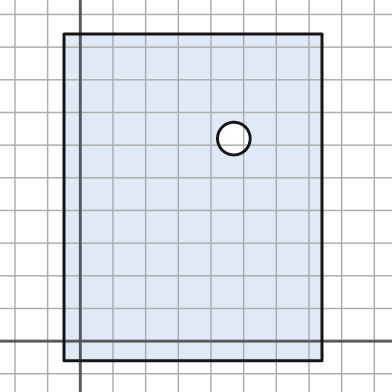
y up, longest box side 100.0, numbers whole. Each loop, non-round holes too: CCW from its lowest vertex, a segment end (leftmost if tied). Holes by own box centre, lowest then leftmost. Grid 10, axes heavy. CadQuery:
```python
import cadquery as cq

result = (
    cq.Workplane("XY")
    .moveTo(-5.0, -6.0)
    .lineTo(74.0, -6.0)
    .lineTo(74.0, 94.0)
    .lineTo(-5.0, 94.0)
    .close()
    .moveTo(47.0, 62.0)
    .circle(5.0)
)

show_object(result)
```